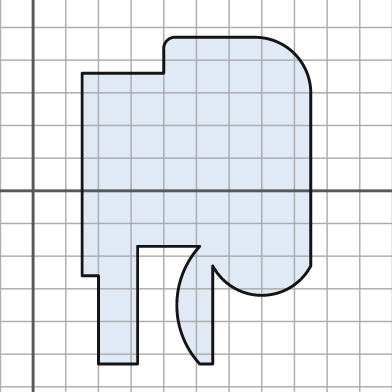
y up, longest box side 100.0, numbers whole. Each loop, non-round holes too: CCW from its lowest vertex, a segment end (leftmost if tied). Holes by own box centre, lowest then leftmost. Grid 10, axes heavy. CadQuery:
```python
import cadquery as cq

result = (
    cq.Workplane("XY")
    .moveTo(20.0, -53.0)
    .lineTo(32.0, -53.0)
    .lineTo(32.0, -17.0)
    .lineTo(51.0, -17.0)
    .threePointArc((44.0, -35.0), (51.0, -53.0))
    .lineTo(55.0, -53.0)
    .lineTo(55.0, -23.0)
    .threePointArc((70.0, -32.0), (85.0, -23.0))
    .lineTo(85.0, 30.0)
    .threePointArc((80.0, 42.0), (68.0, 47.0))
    .lineTo(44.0, 47.0)
    .threePointArc((41.0, 46.0), (40.0, 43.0))
    .lineTo(40.0, 36.0)
    .lineTo(15.0, 36.0)
    .lineTo(15.0, -26.0)
    .lineTo(20.0, -26.0)
    .close()
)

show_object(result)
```